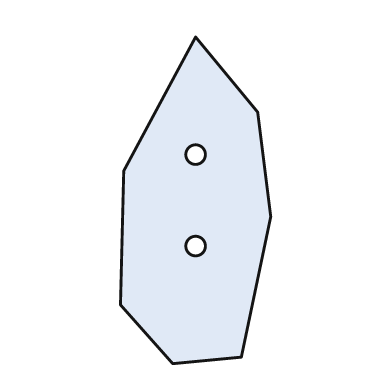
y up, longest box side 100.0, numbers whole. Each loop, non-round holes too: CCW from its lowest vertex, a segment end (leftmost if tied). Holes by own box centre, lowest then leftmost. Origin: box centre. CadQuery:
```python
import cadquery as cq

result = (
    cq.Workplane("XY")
    .moveTo(-7.0, -50.0)
    .lineTo(14.0, -48.0)
    .lineTo(23.0, -5.0)
    .lineTo(19.0, 27.0)
    .lineTo(0.0, 50.0)
    .lineTo(-22.0, 9.0)
    .lineTo(-23.0, -32.0)
    .close()
    .moveTo(0.0, -14.0)
    .circle(3.0)
    .moveTo(0.0, 14.0)
    .circle(3.0)
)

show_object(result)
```